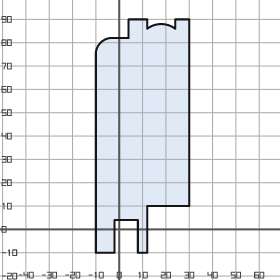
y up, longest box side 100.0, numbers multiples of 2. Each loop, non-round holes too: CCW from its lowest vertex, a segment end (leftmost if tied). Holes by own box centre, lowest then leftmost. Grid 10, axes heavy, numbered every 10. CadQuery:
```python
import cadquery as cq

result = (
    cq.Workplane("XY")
    .moveTo(-10.0, -10.0)
    .lineTo(-2.0, -10.0)
    .lineTo(-2.0, 4.0)
    .lineTo(8.0, 4.0)
    .lineTo(8.0, -10.0)
    .lineTo(12.0, -10.0)
    .lineTo(12.0, 10.0)
    .lineTo(30.0, 10.0)
    .lineTo(30.0, 90.0)
    .lineTo(24.0, 90.0)
    .lineTo(24.0, 86.0)
    .threePointArc((18.0, 88.0), (12.0, 86.0))
    .lineTo(12.0, 90.0)
    .lineTo(4.0, 90.0)
    .lineTo(4.0, 82.0)
    .lineTo(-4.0, 82.0)
    .threePointArc((-8.0, 80.0), (-10.0, 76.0))
    .close()
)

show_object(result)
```